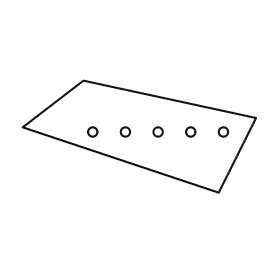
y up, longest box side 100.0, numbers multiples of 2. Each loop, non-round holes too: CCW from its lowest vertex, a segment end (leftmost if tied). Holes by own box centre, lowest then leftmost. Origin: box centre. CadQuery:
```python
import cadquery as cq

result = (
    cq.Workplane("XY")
    .moveTo(34.0, -24.0)
    .lineTo(50.0, 8.0)
    .lineTo(-24.0, 24.0)
    .lineTo(-50.0, 4.0)
    .close()
    .moveTo(-20.0, 2.0)
    .circle(2.0)
    .moveTo(-6.0, 2.0)
    .circle(2.0)
    .moveTo(8.0, 2.0)
    .circle(2.0)
    .moveTo(22.0, 2.0)
    .circle(2.0)
    .moveTo(36.0, 2.0)
    .circle(2.0)
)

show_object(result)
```